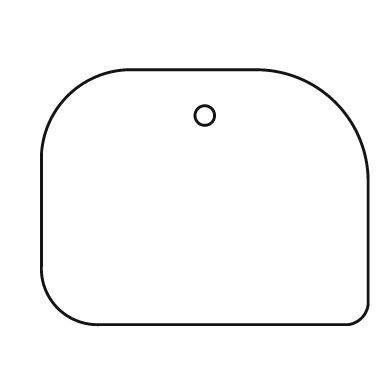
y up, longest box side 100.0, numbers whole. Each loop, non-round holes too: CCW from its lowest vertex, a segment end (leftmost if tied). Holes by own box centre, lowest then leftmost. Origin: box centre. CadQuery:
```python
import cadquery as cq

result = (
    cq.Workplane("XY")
    .moveTo(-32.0, -39.0)
    .lineTo(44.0, -39.0)
    .threePointArc((48.0, -37.0), (50.0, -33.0))
    .lineTo(50.0, 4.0)
    .threePointArc((40.0, 29.0), (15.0, 39.0))
    .lineTo(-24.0, 39.0)
    .threePointArc((-42.0, 31.0), (-50.0, 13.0))
    .lineTo(-50.0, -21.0)
    .threePointArc((-45.0, -34.0), (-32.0, -39.0))
    .close()
    .moveTo(0.0, 25.0)
    .circle(3.0)
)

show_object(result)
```